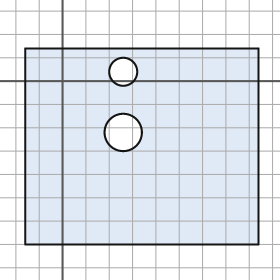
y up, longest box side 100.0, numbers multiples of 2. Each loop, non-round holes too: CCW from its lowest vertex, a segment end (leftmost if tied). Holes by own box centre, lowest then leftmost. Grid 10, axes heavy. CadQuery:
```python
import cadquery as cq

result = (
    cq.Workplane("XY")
    .moveTo(-16.0, -70.0)
    .lineTo(84.0, -70.0)
    .lineTo(84.0, 14.0)
    .lineTo(-16.0, 14.0)
    .close()
    .moveTo(26.0, -22.0)
    .circle(8.0)
    .moveTo(26.0, 4.0)
    .circle(6.0)
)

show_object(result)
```